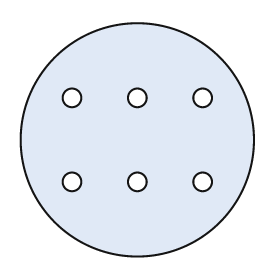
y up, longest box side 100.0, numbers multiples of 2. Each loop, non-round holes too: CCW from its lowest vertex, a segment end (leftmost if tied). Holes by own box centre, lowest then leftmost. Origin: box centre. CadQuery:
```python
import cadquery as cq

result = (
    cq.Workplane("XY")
    .moveTo(0.0, 0.0)
    .circle(50.0)
    .moveTo(-28.0, -18.0)
    .circle(4.0)
    .moveTo(0.0, -18.0)
    .circle(4.0)
    .moveTo(28.0, -18.0)
    .circle(4.0)
    .moveTo(-28.0, 18.0)
    .circle(4.0)
    .moveTo(0.0, 18.0)
    .circle(4.0)
    .moveTo(28.0, 18.0)
    .circle(4.0)
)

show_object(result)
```